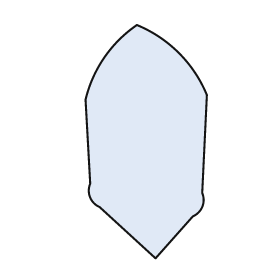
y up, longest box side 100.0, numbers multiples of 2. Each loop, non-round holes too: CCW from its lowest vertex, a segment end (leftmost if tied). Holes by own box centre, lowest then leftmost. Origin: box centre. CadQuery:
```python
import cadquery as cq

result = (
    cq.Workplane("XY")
    .moveTo(4.0, -50.0)
    .lineTo(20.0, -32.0)
    .threePointArc((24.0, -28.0), (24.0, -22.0))
    .lineTo(26.0, 20.0)
    .threePointArc((14.0, 38.0), (-4.0, 50.0))
    .threePointArc((-18.0, 36.0), (-26.0, 18.0))
    .lineTo(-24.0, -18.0)
    .threePointArc((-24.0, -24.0), (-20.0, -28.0))
    .close()
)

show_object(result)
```